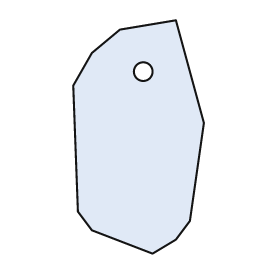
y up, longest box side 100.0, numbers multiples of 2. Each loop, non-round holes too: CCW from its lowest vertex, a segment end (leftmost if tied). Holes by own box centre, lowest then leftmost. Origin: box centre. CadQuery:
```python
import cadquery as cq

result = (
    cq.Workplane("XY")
    .moveTo(6.0, -50.0)
    .lineTo(16.0, -44.0)
    .lineTo(22.0, -36.0)
    .lineTo(28.0, 6.0)
    .lineTo(16.0, 50.0)
    .lineTo(-8.0, 46.0)
    .lineTo(-20.0, 36.0)
    .lineTo(-28.0, 22.0)
    .lineTo(-26.0, -32.0)
    .lineTo(-20.0, -40.0)
    .close()
    .moveTo(2.0, 28.0)
    .circle(4.0)
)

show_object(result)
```